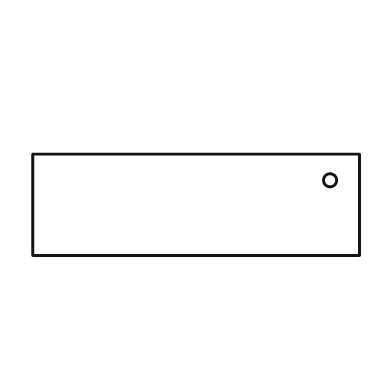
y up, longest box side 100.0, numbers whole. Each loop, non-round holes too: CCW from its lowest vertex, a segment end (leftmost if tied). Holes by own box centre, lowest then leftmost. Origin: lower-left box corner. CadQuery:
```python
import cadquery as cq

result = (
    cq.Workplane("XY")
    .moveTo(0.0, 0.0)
    .lineTo(100.0, 0.0)
    .lineTo(100.0, 31.0)
    .lineTo(0.0, 31.0)
    .close()
    .moveTo(91.0, 23.0)
    .circle(2.0)
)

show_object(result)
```